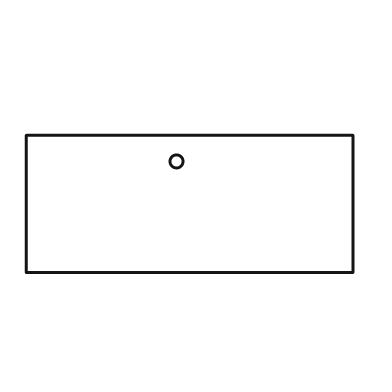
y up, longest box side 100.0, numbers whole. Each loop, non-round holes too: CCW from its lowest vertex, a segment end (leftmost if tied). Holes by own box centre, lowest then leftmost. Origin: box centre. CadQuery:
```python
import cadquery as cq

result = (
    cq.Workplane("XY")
    .moveTo(-50.0, -21.0)
    .lineTo(50.0, -21.0)
    .lineTo(50.0, 21.0)
    .lineTo(-50.0, 21.0)
    .close()
    .moveTo(-4.0, 13.0)
    .circle(2.0)
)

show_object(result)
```